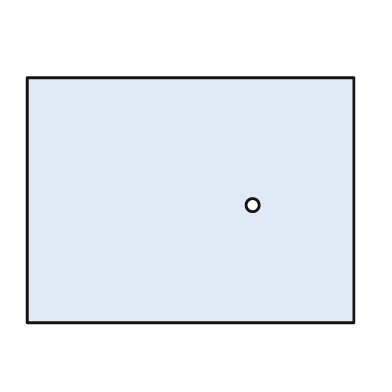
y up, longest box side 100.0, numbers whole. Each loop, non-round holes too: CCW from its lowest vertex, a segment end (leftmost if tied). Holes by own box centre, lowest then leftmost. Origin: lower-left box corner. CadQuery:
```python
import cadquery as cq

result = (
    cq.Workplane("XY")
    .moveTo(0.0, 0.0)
    .lineTo(100.0, 0.0)
    .lineTo(100.0, 75.0)
    .lineTo(0.0, 75.0)
    .close()
    .moveTo(69.0, 36.0)
    .circle(2.0)
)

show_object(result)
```